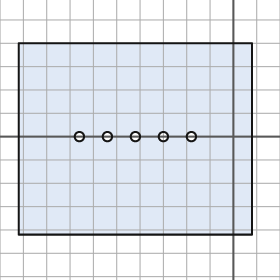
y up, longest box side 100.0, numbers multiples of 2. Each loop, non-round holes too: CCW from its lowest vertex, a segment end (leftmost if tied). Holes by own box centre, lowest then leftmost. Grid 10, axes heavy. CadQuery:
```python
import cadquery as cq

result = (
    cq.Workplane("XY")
    .moveTo(-92.0, -42.0)
    .lineTo(8.0, -42.0)
    .lineTo(8.0, 40.0)
    .lineTo(-92.0, 40.0)
    .close()
    .moveTo(-66.0, 0.0)
    .circle(2.0)
    .moveTo(-54.0, 0.0)
    .circle(2.0)
    .moveTo(-42.0, 0.0)
    .circle(2.0)
    .moveTo(-30.0, 0.0)
    .circle(2.0)
    .moveTo(-18.0, 0.0)
    .circle(2.0)
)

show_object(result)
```